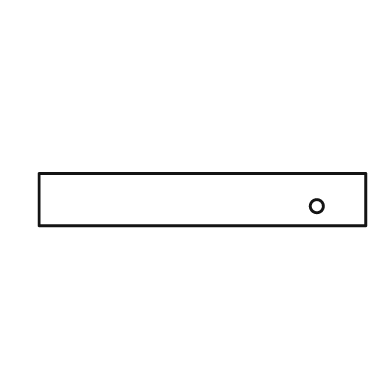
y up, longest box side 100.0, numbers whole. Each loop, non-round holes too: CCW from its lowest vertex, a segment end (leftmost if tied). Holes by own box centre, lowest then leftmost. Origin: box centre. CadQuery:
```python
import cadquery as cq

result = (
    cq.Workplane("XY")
    .moveTo(-50.0, -8.0)
    .lineTo(50.0, -8.0)
    .lineTo(50.0, 8.0)
    .lineTo(-50.0, 8.0)
    .close()
    .moveTo(35.0, -2.0)
    .circle(2.0)
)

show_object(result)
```